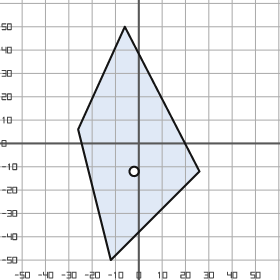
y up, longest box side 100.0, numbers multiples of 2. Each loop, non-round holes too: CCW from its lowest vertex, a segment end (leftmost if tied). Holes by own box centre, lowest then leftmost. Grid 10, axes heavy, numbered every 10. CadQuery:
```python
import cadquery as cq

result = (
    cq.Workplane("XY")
    .moveTo(-12.0, -50.0)
    .lineTo(26.0, -12.0)
    .lineTo(-6.0, 50.0)
    .lineTo(-26.0, 6.0)
    .close()
    .moveTo(-2.0, -12.0)
    .circle(2.0)
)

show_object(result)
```